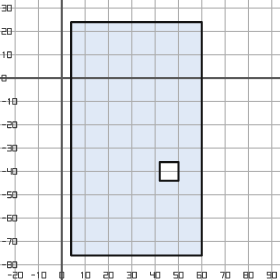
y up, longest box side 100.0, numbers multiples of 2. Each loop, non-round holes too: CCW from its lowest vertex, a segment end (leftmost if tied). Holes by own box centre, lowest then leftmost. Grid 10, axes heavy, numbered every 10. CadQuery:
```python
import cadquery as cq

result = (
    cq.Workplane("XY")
    .moveTo(4.0, -76.0)
    .lineTo(60.0, -76.0)
    .lineTo(60.0, 24.0)
    .lineTo(4.0, 24.0)
    .close()
    .moveTo(42.0, -44.0)
    .lineTo(50.0, -44.0)
    .lineTo(50.0, -36.0)
    .lineTo(42.0, -36.0)
    .close()
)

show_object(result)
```